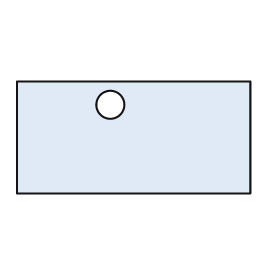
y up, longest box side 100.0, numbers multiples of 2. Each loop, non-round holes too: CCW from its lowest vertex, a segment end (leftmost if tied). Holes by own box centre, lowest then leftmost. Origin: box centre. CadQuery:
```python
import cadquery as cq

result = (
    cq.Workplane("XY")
    .moveTo(-50.0, -24.0)
    .lineTo(50.0, -24.0)
    .lineTo(50.0, 24.0)
    .lineTo(-50.0, 24.0)
    .close()
    .moveTo(-10.0, 14.0)
    .circle(6.0)
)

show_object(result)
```